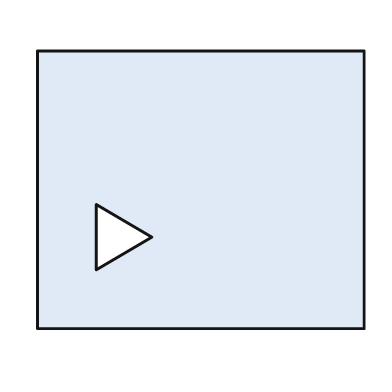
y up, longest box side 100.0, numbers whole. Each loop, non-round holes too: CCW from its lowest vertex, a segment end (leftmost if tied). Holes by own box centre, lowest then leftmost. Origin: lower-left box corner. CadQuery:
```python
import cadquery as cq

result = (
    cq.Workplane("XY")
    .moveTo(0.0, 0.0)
    .lineTo(100.0, 0.0)
    .lineTo(100.0, 85.0)
    .lineTo(0.0, 85.0)
    .close()
    .moveTo(18.0, 18.0)
    .lineTo(35.0, 28.0)
    .lineTo(18.0, 38.0)
    .close()
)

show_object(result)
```